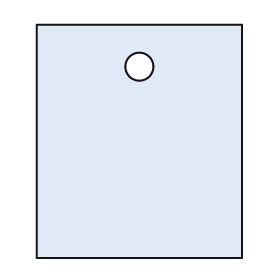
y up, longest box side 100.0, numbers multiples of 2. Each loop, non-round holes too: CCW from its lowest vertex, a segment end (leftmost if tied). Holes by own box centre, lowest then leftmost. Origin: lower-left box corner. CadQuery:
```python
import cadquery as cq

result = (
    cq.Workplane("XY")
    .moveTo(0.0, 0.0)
    .lineTo(88.0, 0.0)
    .lineTo(88.0, 100.0)
    .lineTo(0.0, 100.0)
    .close()
    .moveTo(44.0, 82.0)
    .circle(6.0)
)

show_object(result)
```